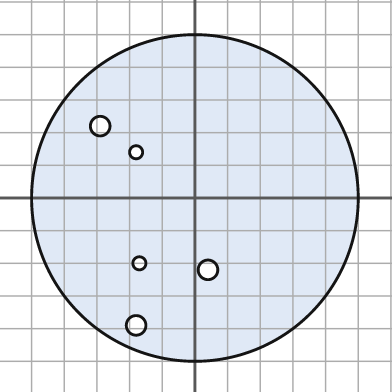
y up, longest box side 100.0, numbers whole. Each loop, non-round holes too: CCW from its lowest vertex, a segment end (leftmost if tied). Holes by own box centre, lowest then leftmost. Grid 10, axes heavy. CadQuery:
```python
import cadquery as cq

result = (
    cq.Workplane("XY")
    .moveTo(0.0, 0.0)
    .circle(50.0)
    .moveTo(-18.0, -39.0)
    .circle(3.0)
    .moveTo(4.0, -22.0)
    .circle(3.0)
    .moveTo(-17.0, -20.0)
    .circle(2.0)
    .moveTo(-18.0, 14.0)
    .circle(2.0)
    .moveTo(-29.0, 22.0)
    .circle(3.0)
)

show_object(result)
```